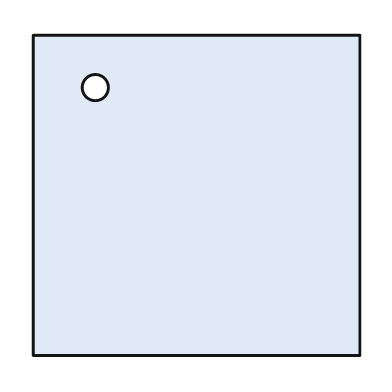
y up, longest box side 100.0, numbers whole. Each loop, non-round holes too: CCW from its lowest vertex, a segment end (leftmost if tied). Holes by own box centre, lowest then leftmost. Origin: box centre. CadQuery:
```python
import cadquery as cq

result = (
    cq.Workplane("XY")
    .moveTo(-50.0, -49.0)
    .lineTo(50.0, -49.0)
    .lineTo(50.0, 49.0)
    .lineTo(-50.0, 49.0)
    .close()
    .moveTo(-31.0, 33.0)
    .circle(4.0)
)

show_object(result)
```